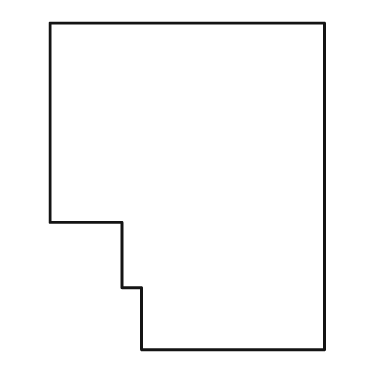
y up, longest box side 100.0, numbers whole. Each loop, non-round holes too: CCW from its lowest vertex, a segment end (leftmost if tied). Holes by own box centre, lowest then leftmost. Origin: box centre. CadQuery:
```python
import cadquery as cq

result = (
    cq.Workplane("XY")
    .moveTo(-14.0, -50.0)
    .lineTo(42.0, -50.0)
    .lineTo(42.0, 50.0)
    .lineTo(-42.0, 50.0)
    .lineTo(-42.0, -11.0)
    .lineTo(-20.0, -11.0)
    .lineTo(-20.0, -31.0)
    .lineTo(-14.0, -31.0)
    .close()
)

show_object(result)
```